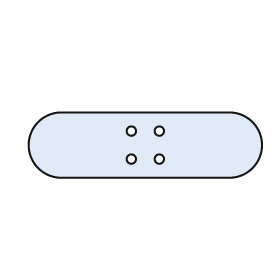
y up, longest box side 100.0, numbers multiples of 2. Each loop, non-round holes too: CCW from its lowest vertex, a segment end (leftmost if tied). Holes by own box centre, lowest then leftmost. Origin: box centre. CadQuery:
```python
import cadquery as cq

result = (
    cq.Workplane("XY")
    .moveTo(-36.0, -14.0)
    .lineTo(36.0, -14.0)
    .threePointArc((50.0, 0.0), (36.0, 14.0))
    .lineTo(-36.0, 14.0)
    .threePointArc((-50.0, 0.0), (-36.0, -14.0))
    .close()
    .moveTo(-6.0, -6.0)
    .circle(2.0)
    .moveTo(6.0, -6.0)
    .circle(2.0)
    .moveTo(-6.0, 6.0)
    .circle(2.0)
    .moveTo(6.0, 6.0)
    .circle(2.0)
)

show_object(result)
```